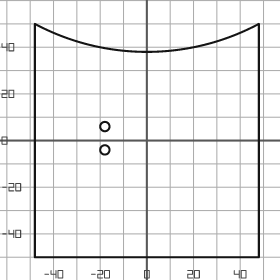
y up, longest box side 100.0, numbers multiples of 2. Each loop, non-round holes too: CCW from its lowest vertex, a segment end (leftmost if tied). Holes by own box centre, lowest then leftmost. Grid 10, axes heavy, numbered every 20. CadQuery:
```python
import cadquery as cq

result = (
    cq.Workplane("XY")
    .moveTo(-48.0, -50.0)
    .lineTo(48.0, -50.0)
    .lineTo(48.0, 50.0)
    .threePointArc((0.0, 38.0), (-48.0, 50.0))
    .close()
    .moveTo(-18.0, -4.0)
    .circle(2.0)
    .moveTo(-18.0, 6.0)
    .circle(2.0)
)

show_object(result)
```